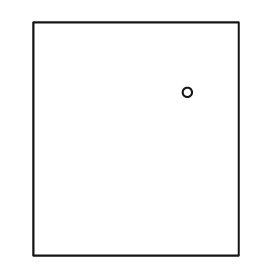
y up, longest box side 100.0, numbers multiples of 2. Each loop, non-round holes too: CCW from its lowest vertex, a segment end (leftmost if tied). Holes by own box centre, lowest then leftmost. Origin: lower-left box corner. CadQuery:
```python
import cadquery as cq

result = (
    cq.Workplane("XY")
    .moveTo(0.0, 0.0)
    .lineTo(88.0, 0.0)
    .lineTo(88.0, 100.0)
    .lineTo(0.0, 100.0)
    .close()
    .moveTo(66.0, 70.0)
    .circle(2.0)
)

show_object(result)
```